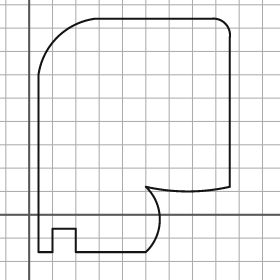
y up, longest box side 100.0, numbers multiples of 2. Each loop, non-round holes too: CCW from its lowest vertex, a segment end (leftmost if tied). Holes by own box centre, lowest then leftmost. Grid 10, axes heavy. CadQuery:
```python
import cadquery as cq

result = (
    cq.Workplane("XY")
    .moveTo(4.0, -16.0)
    .lineTo(10.0, -16.0)
    .lineTo(10.0, -6.0)
    .lineTo(20.0, -6.0)
    .lineTo(20.0, -16.0)
    .lineTo(50.0, -16.0)
    .threePointArc((56.0, -2.0), (50.0, 12.0))
    .threePointArc((68.0, 10.0), (86.0, 12.0))
    .lineTo(86.0, 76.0)
    .threePointArc((84.0, 82.0), (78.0, 84.0))
    .lineTo(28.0, 84.0)
    .threePointArc((12.0, 76.0), (4.0, 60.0))
    .close()
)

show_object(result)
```